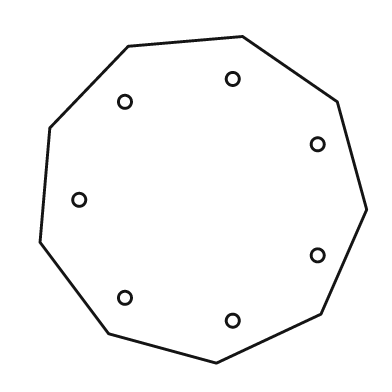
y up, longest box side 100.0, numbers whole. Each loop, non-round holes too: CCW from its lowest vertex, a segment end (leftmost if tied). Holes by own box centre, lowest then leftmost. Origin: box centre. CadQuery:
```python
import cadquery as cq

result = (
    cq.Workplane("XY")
    .moveTo(4.0, -50.0)
    .lineTo(36.0, -35.0)
    .lineTo(50.0, -3.0)
    .lineTo(41.0, 30.0)
    .lineTo(12.0, 50.0)
    .lineTo(-23.0, 47.0)
    .lineTo(-47.0, 22.0)
    .lineTo(-50.0, -13.0)
    .lineTo(-29.0, -41.0)
    .close()
    .moveTo(9.0, -37.0)
    .circle(2.0)
    .moveTo(-24.0, -30.0)
    .circle(2.0)
    .moveTo(35.0, -17.0)
    .circle(2.0)
    .moveTo(-38.0, 0.0)
    .circle(2.0)
    .moveTo(35.0, 17.0)
    .circle(2.0)
    .moveTo(-24.0, 30.0)
    .circle(2.0)
    .moveTo(9.0, 37.0)
    .circle(2.0)
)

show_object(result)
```